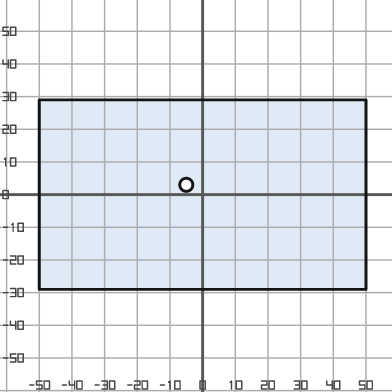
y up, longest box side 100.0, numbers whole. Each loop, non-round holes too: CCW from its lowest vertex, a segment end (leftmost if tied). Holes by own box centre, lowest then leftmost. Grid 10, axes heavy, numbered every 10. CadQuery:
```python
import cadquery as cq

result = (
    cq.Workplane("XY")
    .moveTo(-50.0, -29.0)
    .lineTo(50.0, -29.0)
    .lineTo(50.0, 29.0)
    .lineTo(-50.0, 29.0)
    .close()
    .moveTo(-5.0, 3.0)
    .circle(2.0)
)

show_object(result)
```